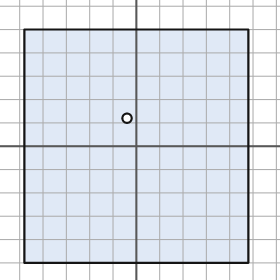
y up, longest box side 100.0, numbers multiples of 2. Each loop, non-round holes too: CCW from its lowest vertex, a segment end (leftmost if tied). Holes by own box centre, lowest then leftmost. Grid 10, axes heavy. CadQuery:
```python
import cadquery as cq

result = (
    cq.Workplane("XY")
    .moveTo(-48.0, -50.0)
    .lineTo(48.0, -50.0)
    .lineTo(48.0, 50.0)
    .lineTo(-48.0, 50.0)
    .close()
    .moveTo(-4.0, 12.0)
    .circle(2.0)
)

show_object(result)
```